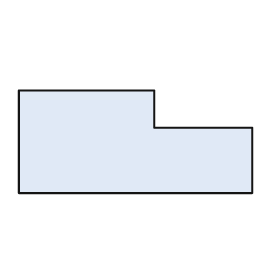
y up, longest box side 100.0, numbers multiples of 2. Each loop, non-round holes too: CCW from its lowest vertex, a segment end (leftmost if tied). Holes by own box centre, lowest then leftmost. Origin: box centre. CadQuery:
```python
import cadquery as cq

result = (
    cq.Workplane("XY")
    .moveTo(-50.0, -22.0)
    .lineTo(50.0, -22.0)
    .lineTo(50.0, 6.0)
    .lineTo(8.0, 6.0)
    .lineTo(8.0, 22.0)
    .lineTo(-50.0, 22.0)
    .close()
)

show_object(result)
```